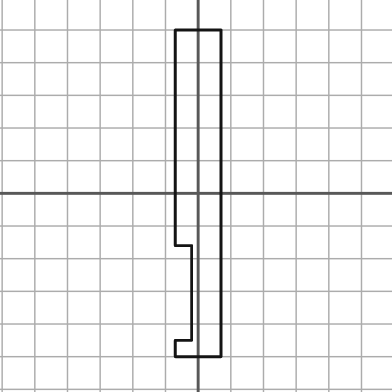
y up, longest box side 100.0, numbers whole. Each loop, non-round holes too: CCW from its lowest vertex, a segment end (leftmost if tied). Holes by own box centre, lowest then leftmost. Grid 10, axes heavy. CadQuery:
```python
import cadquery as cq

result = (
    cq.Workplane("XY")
    .moveTo(-7.0, -50.0)
    .lineTo(7.0, -50.0)
    .lineTo(7.0, 50.0)
    .lineTo(-7.0, 50.0)
    .lineTo(-7.0, -16.0)
    .lineTo(-2.0, -16.0)
    .lineTo(-2.0, -45.0)
    .lineTo(-7.0, -45.0)
    .close()
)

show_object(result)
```